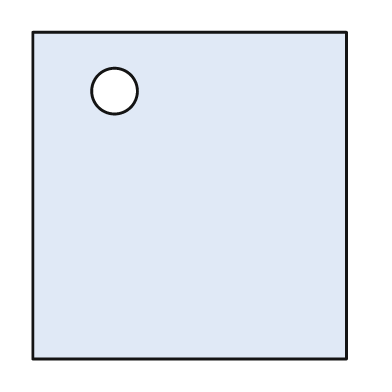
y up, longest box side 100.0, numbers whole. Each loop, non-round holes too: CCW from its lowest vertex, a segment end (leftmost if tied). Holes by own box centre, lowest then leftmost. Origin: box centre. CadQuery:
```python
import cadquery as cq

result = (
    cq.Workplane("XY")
    .moveTo(-48.0, -50.0)
    .lineTo(48.0, -50.0)
    .lineTo(48.0, 50.0)
    .lineTo(-48.0, 50.0)
    .close()
    .moveTo(-23.0, 32.0)
    .circle(7.0)
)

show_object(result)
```